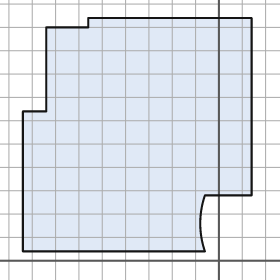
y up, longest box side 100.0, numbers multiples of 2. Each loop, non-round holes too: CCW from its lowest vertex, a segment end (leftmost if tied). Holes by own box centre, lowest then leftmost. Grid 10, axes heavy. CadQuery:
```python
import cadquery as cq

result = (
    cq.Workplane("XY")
    .moveTo(-84.0, 4.0)
    .lineTo(-6.0, 4.0)
    .threePointArc((-8.0, 16.0), (-6.0, 28.0))
    .lineTo(14.0, 28.0)
    .lineTo(14.0, 104.0)
    .lineTo(-56.0, 104.0)
    .lineTo(-56.0, 100.0)
    .lineTo(-74.0, 100.0)
    .lineTo(-74.0, 64.0)
    .lineTo(-84.0, 64.0)
    .close()
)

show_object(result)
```